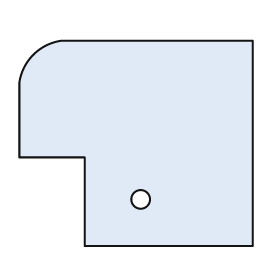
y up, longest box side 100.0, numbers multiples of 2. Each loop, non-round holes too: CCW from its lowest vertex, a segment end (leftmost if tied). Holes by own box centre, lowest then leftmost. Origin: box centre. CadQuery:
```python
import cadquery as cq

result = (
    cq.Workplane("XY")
    .moveTo(-22.0, -44.0)
    .lineTo(50.0, -44.0)
    .lineTo(50.0, 44.0)
    .lineTo(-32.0, 44.0)
    .threePointArc((-44.0, 38.0), (-50.0, 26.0))
    .lineTo(-50.0, -6.0)
    .lineTo(-22.0, -6.0)
    .close()
    .moveTo(2.0, -24.0)
    .circle(4.0)
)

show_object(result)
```